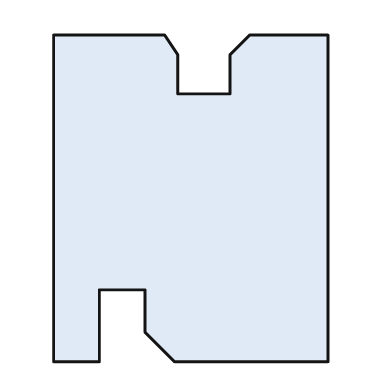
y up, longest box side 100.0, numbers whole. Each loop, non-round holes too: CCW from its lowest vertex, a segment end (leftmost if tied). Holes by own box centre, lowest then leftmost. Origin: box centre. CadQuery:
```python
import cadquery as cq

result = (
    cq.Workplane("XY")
    .moveTo(-42.0, -50.0)
    .lineTo(-28.0, -50.0)
    .lineTo(-28.0, -28.0)
    .lineTo(-14.0, -28.0)
    .lineTo(-14.0, -41.0)
    .lineTo(-5.0, -50.0)
    .lineTo(42.0, -50.0)
    .lineTo(42.0, 50.0)
    .lineTo(18.0, 50.0)
    .lineTo(12.0, 44.0)
    .lineTo(12.0, 32.0)
    .lineTo(-4.0, 32.0)
    .lineTo(-4.0, 44.0)
    .lineTo(-8.0, 50.0)
    .lineTo(-42.0, 50.0)
    .close()
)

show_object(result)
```